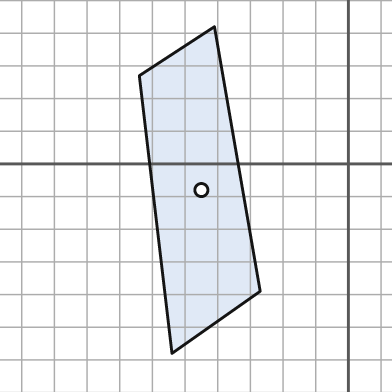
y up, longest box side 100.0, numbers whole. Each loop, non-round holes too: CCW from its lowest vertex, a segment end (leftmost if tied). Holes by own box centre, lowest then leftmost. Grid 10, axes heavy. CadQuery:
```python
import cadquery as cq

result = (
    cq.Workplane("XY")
    .moveTo(-54.0, -58.0)
    .lineTo(-27.0, -39.0)
    .lineTo(-41.0, 42.0)
    .lineTo(-64.0, 27.0)
    .close()
    .moveTo(-45.0, -8.0)
    .circle(2.0)
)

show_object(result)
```